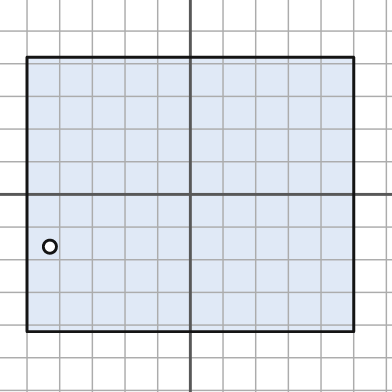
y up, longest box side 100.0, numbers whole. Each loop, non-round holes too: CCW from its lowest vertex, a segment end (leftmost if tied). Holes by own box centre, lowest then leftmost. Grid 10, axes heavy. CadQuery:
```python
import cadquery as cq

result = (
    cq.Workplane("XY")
    .moveTo(-50.0, -42.0)
    .lineTo(50.0, -42.0)
    .lineTo(50.0, 42.0)
    .lineTo(-50.0, 42.0)
    .close()
    .moveTo(-43.0, -16.0)
    .circle(2.0)
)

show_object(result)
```